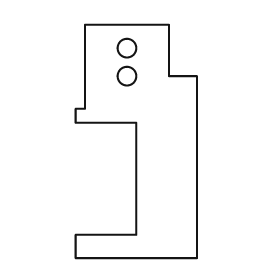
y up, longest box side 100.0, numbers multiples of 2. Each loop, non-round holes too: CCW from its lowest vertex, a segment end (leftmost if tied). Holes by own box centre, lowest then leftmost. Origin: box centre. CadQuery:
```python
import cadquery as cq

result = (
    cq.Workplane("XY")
    .moveTo(-26.0, -50.0)
    .lineTo(26.0, -50.0)
    .lineTo(26.0, 28.0)
    .lineTo(14.0, 28.0)
    .lineTo(14.0, 50.0)
    .lineTo(-22.0, 50.0)
    .lineTo(-22.0, 14.0)
    .lineTo(-26.0, 14.0)
    .lineTo(-26.0, 8.0)
    .lineTo(0.0, 8.0)
    .lineTo(0.0, -40.0)
    .lineTo(-26.0, -40.0)
    .close()
    .moveTo(-4.0, 28.0)
    .circle(4.0)
    .moveTo(-4.0, 40.0)
    .circle(4.0)
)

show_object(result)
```